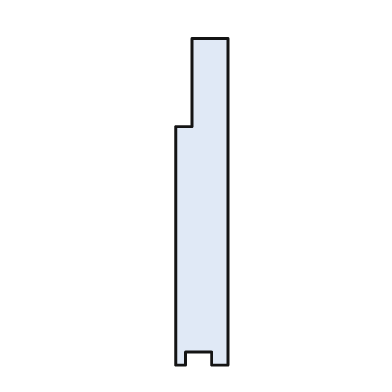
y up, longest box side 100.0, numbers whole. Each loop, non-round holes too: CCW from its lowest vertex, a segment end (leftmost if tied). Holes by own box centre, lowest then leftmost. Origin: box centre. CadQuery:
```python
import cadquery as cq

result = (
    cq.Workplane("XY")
    .moveTo(-8.0, -50.0)
    .lineTo(-5.0, -50.0)
    .lineTo(-5.0, -46.0)
    .lineTo(3.0, -46.0)
    .lineTo(3.0, -50.0)
    .lineTo(8.0, -50.0)
    .lineTo(8.0, 50.0)
    .lineTo(-3.0, 50.0)
    .lineTo(-3.0, 23.0)
    .lineTo(-8.0, 23.0)
    .close()
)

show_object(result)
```